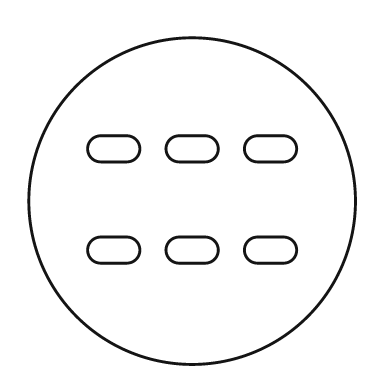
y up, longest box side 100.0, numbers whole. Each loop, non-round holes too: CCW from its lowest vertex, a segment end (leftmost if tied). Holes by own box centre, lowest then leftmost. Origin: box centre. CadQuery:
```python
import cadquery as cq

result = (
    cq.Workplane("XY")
    .moveTo(0.0, 0.0)
    .circle(50.0)
    .moveTo(-28.0, -19.0)
    .lineTo(-20.0, -19.0)
    .threePointArc((-16.0, -15.0), (-20.0, -11.0))
    .lineTo(-28.0, -11.0)
    .threePointArc((-32.0, -15.0), (-28.0, -19.0))
    .close()
    .moveTo(-4.0, -19.0)
    .lineTo(4.0, -19.0)
    .threePointArc((8.0, -15.0), (4.0, -11.0))
    .lineTo(-4.0, -11.0)
    .threePointArc((-8.0, -15.0), (-4.0, -19.0))
    .close()
    .moveTo(20.0, -19.0)
    .lineTo(28.0, -19.0)
    .threePointArc((32.0, -15.0), (28.0, -11.0))
    .lineTo(20.0, -11.0)
    .threePointArc((16.0, -15.0), (20.0, -19.0))
    .close()
    .moveTo(-28.0, 12.0)
    .lineTo(-20.0, 12.0)
    .threePointArc((-16.0, 16.0), (-20.0, 20.0))
    .lineTo(-28.0, 20.0)
    .threePointArc((-32.0, 16.0), (-28.0, 12.0))
    .close()
    .moveTo(-4.0, 12.0)
    .lineTo(4.0, 12.0)
    .threePointArc((8.0, 16.0), (4.0, 20.0))
    .lineTo(-4.0, 20.0)
    .threePointArc((-8.0, 16.0), (-4.0, 12.0))
    .close()
    .moveTo(20.0, 12.0)
    .lineTo(28.0, 12.0)
    .threePointArc((32.0, 16.0), (28.0, 20.0))
    .lineTo(20.0, 20.0)
    .threePointArc((16.0, 16.0), (20.0, 12.0))
    .close()
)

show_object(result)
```